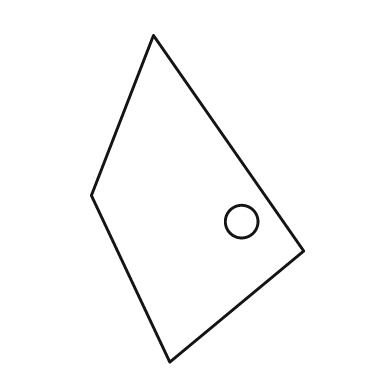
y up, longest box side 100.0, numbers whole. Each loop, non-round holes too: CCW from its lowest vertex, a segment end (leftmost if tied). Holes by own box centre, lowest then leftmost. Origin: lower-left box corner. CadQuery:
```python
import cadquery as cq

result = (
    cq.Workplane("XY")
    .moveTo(24.0, 0.0)
    .lineTo(65.0, 34.0)
    .lineTo(19.0, 100.0)
    .lineTo(0.0, 51.0)
    .close()
    .moveTo(46.0, 43.0)
    .circle(5.0)
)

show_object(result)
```